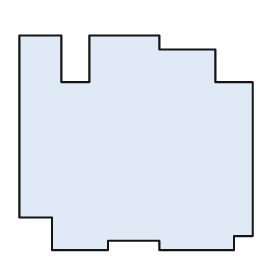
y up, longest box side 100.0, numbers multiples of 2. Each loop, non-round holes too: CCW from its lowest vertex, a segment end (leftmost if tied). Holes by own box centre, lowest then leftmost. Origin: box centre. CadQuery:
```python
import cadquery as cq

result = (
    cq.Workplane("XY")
    .moveTo(-36.0, -46.0)
    .lineTo(-12.0, -46.0)
    .lineTo(-12.0, -42.0)
    .lineTo(10.0, -42.0)
    .lineTo(10.0, -46.0)
    .lineTo(42.0, -46.0)
    .lineTo(42.0, -40.0)
    .lineTo(50.0, -40.0)
    .lineTo(50.0, 26.0)
    .lineTo(34.0, 26.0)
    .lineTo(34.0, 40.0)
    .lineTo(10.0, 40.0)
    .lineTo(10.0, 46.0)
    .lineTo(-20.0, 46.0)
    .lineTo(-20.0, 26.0)
    .lineTo(-32.0, 26.0)
    .lineTo(-32.0, 46.0)
    .lineTo(-50.0, 46.0)
    .lineTo(-50.0, -32.0)
    .lineTo(-36.0, -32.0)
    .close()
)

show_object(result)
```